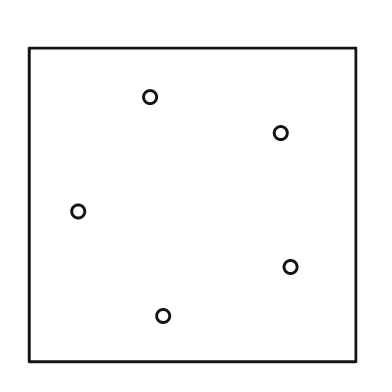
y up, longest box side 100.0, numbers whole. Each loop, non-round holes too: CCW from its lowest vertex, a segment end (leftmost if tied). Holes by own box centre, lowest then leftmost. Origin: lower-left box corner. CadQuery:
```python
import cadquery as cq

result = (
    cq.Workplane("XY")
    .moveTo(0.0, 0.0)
    .lineTo(100.0, 0.0)
    .lineTo(100.0, 96.0)
    .lineTo(0.0, 96.0)
    .close()
    .moveTo(41.0, 14.0)
    .circle(2.0)
    .moveTo(80.0, 29.0)
    .circle(2.0)
    .moveTo(15.0, 46.0)
    .circle(2.0)
    .moveTo(77.0, 70.0)
    .circle(2.0)
    .moveTo(37.0, 81.0)
    .circle(2.0)
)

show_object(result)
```